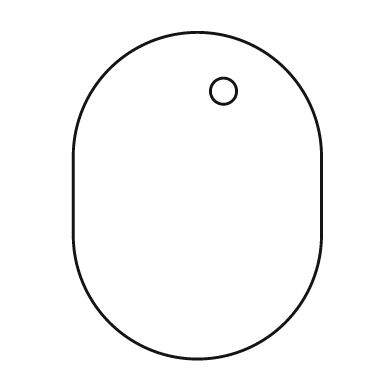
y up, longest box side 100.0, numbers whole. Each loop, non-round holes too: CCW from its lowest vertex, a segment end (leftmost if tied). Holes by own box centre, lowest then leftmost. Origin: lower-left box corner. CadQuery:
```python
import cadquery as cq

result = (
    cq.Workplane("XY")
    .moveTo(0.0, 38.0)
    .threePointArc((38.0, 0.0), (76.0, 38.0))
    .lineTo(76.0, 62.0)
    .threePointArc((38.0, 100.0), (0.0, 62.0))
    .close()
    .moveTo(46.0, 82.0)
    .circle(4.0)
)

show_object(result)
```